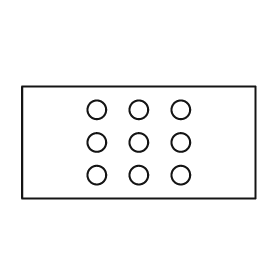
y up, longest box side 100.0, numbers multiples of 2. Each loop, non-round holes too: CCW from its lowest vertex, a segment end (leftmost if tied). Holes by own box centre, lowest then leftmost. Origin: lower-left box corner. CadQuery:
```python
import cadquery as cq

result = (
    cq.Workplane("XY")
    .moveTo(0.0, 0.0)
    .lineTo(100.0, 0.0)
    .lineTo(100.0, 48.0)
    .lineTo(0.0, 48.0)
    .close()
    .moveTo(32.0, 10.0)
    .circle(4.0)
    .moveTo(50.0, 10.0)
    .circle(4.0)
    .moveTo(68.0, 10.0)
    .circle(4.0)
    .moveTo(32.0, 24.0)
    .circle(4.0)
    .moveTo(50.0, 24.0)
    .circle(4.0)
    .moveTo(68.0, 24.0)
    .circle(4.0)
    .moveTo(32.0, 38.0)
    .circle(4.0)
    .moveTo(50.0, 38.0)
    .circle(4.0)
    .moveTo(68.0, 38.0)
    .circle(4.0)
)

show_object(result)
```